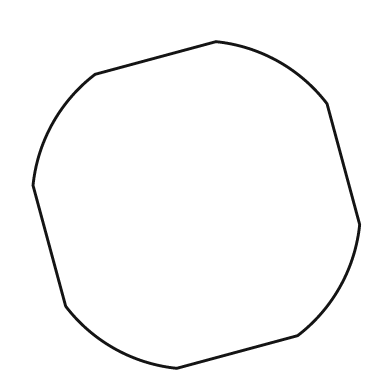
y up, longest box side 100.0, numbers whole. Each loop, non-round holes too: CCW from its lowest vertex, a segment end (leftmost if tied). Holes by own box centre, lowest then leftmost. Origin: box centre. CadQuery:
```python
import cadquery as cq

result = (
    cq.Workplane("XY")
    .moveTo(-6.0, -50.0)
    .lineTo(31.0, -40.0)
    .threePointArc((44.0, -25.0), (50.0, -6.0))
    .lineTo(40.0, 31.0)
    .threePointArc((25.0, 44.0), (6.0, 50.0))
    .lineTo(-31.0, 40.0)
    .threePointArc((-44.0, 25.0), (-50.0, 6.0))
    .lineTo(-40.0, -31.0)
    .threePointArc((-25.0, -44.0), (-6.0, -50.0))
    .close()
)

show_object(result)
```